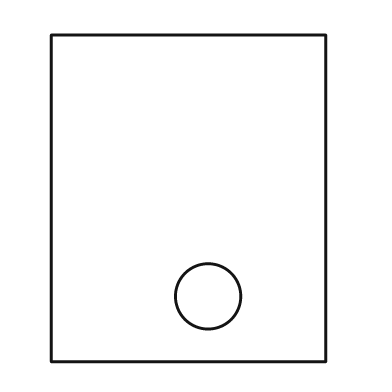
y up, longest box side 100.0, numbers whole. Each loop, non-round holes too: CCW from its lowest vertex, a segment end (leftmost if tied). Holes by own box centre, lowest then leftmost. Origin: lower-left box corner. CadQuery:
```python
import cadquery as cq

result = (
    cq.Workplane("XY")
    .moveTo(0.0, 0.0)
    .lineTo(84.0, 0.0)
    .lineTo(84.0, 100.0)
    .lineTo(0.0, 100.0)
    .close()
    .moveTo(48.0, 20.0)
    .circle(10.0)
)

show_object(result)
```